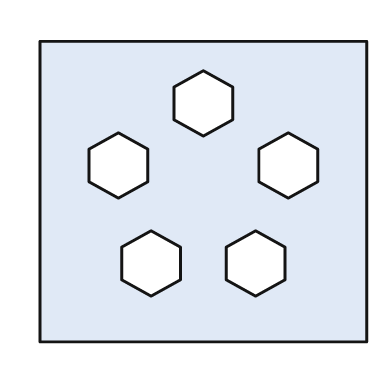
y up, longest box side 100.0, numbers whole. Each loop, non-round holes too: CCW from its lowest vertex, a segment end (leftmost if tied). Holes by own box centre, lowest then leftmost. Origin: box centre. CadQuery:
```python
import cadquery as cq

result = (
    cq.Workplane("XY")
    .moveTo(-50.0, -46.0)
    .lineTo(50.0, -46.0)
    .lineTo(50.0, 46.0)
    .lineTo(-50.0, 46.0)
    .close()
    .moveTo(-16.0, -32.0)
    .lineTo(-7.0, -27.0)
    .lineTo(-7.0, -17.0)
    .lineTo(-16.0, -12.0)
    .lineTo(-25.0, -17.0)
    .lineTo(-25.0, -27.0)
    .close()
    .moveTo(16.0, -32.0)
    .lineTo(25.0, -27.0)
    .lineTo(25.0, -17.0)
    .lineTo(16.0, -12.0)
    .lineTo(7.0, -17.0)
    .lineTo(7.0, -27.0)
    .close()
    .moveTo(-26.0, -2.0)
    .lineTo(-17.0, 3.0)
    .lineTo(-17.0, 13.0)
    .lineTo(-26.0, 18.0)
    .lineTo(-35.0, 13.0)
    .lineTo(-35.0, 3.0)
    .close()
    .moveTo(26.0, -2.0)
    .lineTo(35.0, 3.0)
    .lineTo(35.0, 13.0)
    .lineTo(26.0, 18.0)
    .lineTo(17.0, 13.0)
    .lineTo(17.0, 3.0)
    .close()
    .moveTo(0.0, 17.0)
    .lineTo(9.0, 22.0)
    .lineTo(9.0, 32.0)
    .lineTo(0.0, 37.0)
    .lineTo(-9.0, 32.0)
    .lineTo(-9.0, 22.0)
    .close()
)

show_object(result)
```